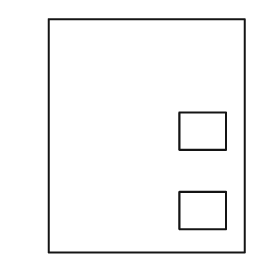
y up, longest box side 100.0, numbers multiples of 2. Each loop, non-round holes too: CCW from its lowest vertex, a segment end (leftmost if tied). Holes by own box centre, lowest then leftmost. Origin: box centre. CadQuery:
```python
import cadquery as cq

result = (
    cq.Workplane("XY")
    .moveTo(-42.0, -50.0)
    .lineTo(42.0, -50.0)
    .lineTo(42.0, 50.0)
    .lineTo(-42.0, 50.0)
    .close()
    .moveTo(14.0, -40.0)
    .lineTo(34.0, -40.0)
    .lineTo(34.0, -24.0)
    .lineTo(14.0, -24.0)
    .close()
    .moveTo(14.0, -6.0)
    .lineTo(34.0, -6.0)
    .lineTo(34.0, 10.0)
    .lineTo(14.0, 10.0)
    .close()
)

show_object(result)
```